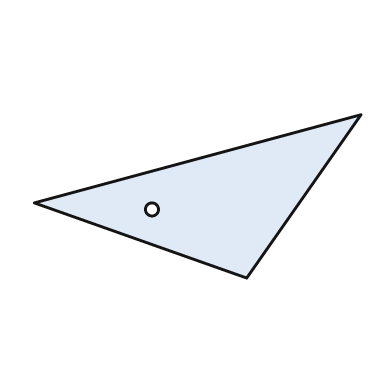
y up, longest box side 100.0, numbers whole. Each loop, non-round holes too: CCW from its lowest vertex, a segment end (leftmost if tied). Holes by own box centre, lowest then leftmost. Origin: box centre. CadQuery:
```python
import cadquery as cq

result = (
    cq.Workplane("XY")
    .moveTo(15.0, -25.0)
    .lineTo(50.0, 25.0)
    .lineTo(-50.0, -2.0)
    .close()
    .moveTo(-14.0, -4.0)
    .circle(2.0)
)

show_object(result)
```